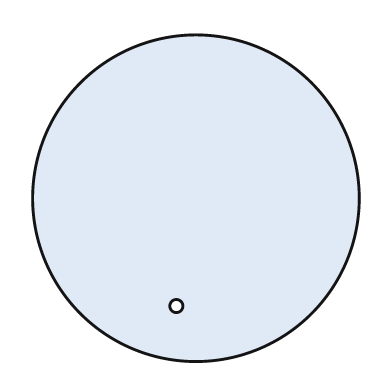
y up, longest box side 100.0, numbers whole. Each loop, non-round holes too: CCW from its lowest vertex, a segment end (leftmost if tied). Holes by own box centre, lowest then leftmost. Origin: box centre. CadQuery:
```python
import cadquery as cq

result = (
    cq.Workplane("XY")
    .moveTo(0.0, 0.0)
    .circle(50.0)
    .moveTo(-6.0, -33.0)
    .circle(2.0)
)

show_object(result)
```